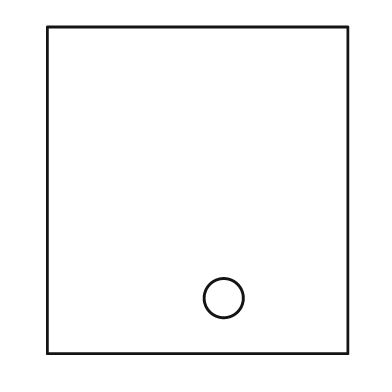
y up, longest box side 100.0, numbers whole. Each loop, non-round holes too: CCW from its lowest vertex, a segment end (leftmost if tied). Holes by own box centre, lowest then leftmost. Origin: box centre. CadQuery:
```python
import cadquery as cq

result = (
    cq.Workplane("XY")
    .moveTo(-46.0, -50.0)
    .lineTo(46.0, -50.0)
    .lineTo(46.0, 50.0)
    .lineTo(-46.0, 50.0)
    .close()
    .moveTo(8.0, -33.0)
    .circle(6.0)
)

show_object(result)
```